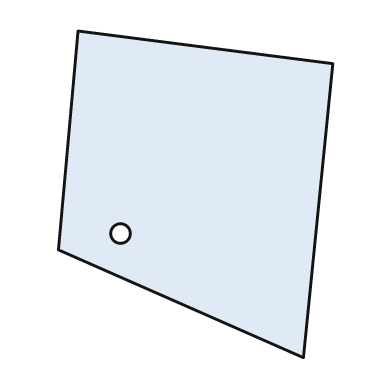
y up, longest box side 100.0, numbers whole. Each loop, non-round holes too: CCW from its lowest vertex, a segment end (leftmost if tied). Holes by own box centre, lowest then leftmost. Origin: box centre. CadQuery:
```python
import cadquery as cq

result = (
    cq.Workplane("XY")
    .moveTo(33.0, -50.0)
    .lineTo(42.0, 40.0)
    .lineTo(-36.0, 50.0)
    .lineTo(-42.0, -17.0)
    .close()
    .moveTo(-23.0, -12.0)
    .circle(3.0)
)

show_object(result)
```